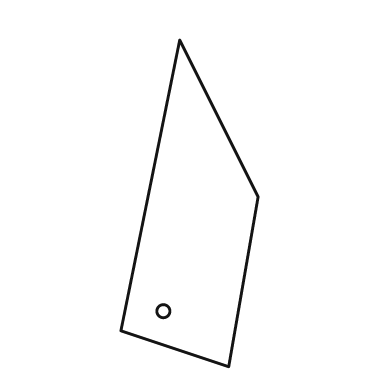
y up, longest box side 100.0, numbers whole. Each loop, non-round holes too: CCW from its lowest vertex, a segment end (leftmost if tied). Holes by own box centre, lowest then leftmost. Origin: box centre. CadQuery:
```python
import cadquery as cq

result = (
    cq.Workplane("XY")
    .moveTo(12.0, -50.0)
    .lineTo(21.0, 2.0)
    .lineTo(-3.0, 50.0)
    .lineTo(-21.0, -39.0)
    .close()
    .moveTo(-8.0, -33.0)
    .circle(2.0)
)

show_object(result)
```